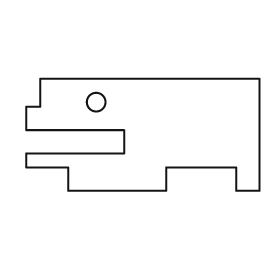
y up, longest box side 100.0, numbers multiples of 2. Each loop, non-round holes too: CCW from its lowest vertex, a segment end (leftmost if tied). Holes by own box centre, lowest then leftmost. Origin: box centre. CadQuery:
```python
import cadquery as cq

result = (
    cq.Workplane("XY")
    .moveTo(-32.0, -24.0)
    .lineTo(10.0, -24.0)
    .lineTo(10.0, -14.0)
    .lineTo(40.0, -14.0)
    .lineTo(40.0, -24.0)
    .lineTo(50.0, -24.0)
    .lineTo(50.0, 24.0)
    .lineTo(-44.0, 24.0)
    .lineTo(-44.0, 12.0)
    .lineTo(-50.0, 12.0)
    .lineTo(-50.0, 2.0)
    .lineTo(-8.0, 2.0)
    .lineTo(-8.0, -8.0)
    .lineTo(-50.0, -8.0)
    .lineTo(-50.0, -14.0)
    .lineTo(-32.0, -14.0)
    .close()
    .moveTo(-20.0, 14.0)
    .circle(4.0)
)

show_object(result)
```